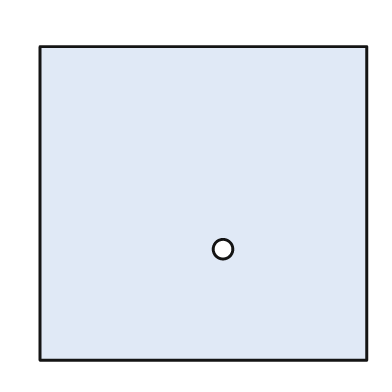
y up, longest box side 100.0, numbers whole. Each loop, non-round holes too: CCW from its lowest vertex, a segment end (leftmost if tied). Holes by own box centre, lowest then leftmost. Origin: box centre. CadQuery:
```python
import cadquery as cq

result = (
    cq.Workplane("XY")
    .moveTo(-50.0, -48.0)
    .lineTo(50.0, -48.0)
    .lineTo(50.0, 48.0)
    .lineTo(-50.0, 48.0)
    .close()
    .moveTo(6.0, -14.0)
    .circle(3.0)
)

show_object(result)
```